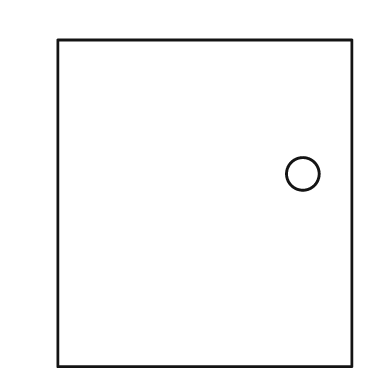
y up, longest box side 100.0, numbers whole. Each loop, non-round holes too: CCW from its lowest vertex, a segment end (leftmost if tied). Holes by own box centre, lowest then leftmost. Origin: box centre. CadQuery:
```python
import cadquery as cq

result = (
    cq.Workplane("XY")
    .moveTo(-45.0, -50.0)
    .lineTo(45.0, -50.0)
    .lineTo(45.0, 50.0)
    .lineTo(-45.0, 50.0)
    .close()
    .moveTo(30.0, 9.0)
    .circle(5.0)
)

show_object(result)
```